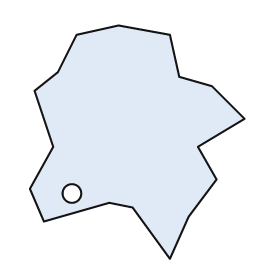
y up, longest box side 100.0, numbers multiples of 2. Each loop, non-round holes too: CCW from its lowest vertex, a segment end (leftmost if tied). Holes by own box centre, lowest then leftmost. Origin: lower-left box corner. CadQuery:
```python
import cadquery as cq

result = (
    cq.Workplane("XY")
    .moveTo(60.0, 0.0)
    .lineTo(68.0, 18.0)
    .lineTo(80.0, 34.0)
    .lineTo(72.0, 48.0)
    .lineTo(92.0, 60.0)
    .lineTo(78.0, 74.0)
    .lineTo(64.0, 78.0)
    .lineTo(60.0, 96.0)
    .lineTo(38.0, 100.0)
    .lineTo(20.0, 96.0)
    .lineTo(12.0, 80.0)
    .lineTo(2.0, 72.0)
    .lineTo(10.0, 48.0)
    .lineTo(0.0, 30.0)
    .lineTo(6.0, 16.0)
    .lineTo(34.0, 24.0)
    .lineTo(44.0, 22.0)
    .close()
    .moveTo(18.0, 28.0)
    .circle(4.0)
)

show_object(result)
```